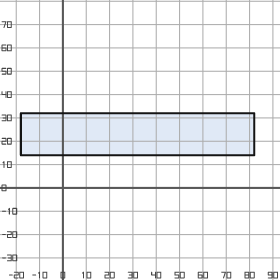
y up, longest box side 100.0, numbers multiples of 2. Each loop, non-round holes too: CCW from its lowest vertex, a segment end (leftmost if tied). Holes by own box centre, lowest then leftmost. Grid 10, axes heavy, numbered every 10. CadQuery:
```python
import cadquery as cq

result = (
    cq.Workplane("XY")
    .moveTo(-18.0, 14.0)
    .lineTo(82.0, 14.0)
    .lineTo(82.0, 32.0)
    .lineTo(-18.0, 32.0)
    .close()
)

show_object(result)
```